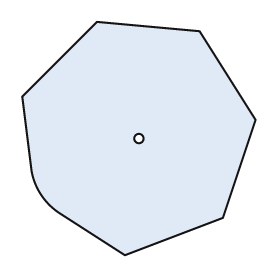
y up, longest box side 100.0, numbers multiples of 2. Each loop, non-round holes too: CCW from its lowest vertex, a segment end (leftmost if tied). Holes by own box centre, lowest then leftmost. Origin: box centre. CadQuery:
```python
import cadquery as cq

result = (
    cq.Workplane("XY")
    .moveTo(-6.0, -50.0)
    .lineTo(36.0, -34.0)
    .lineTo(50.0, 8.0)
    .lineTo(26.0, 46.0)
    .lineTo(-18.0, 50.0)
    .lineTo(-50.0, 18.0)
    .lineTo(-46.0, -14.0)
    .threePointArc((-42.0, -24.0), (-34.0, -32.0))
    .close()
    .moveTo(0.0, 0.0)
    .circle(2.0)
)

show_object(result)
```